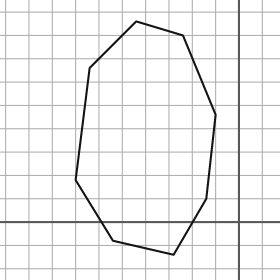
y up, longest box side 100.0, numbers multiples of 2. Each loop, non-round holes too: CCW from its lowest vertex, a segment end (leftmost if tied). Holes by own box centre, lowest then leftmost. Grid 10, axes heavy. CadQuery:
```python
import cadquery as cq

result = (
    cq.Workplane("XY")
    .moveTo(-28.0, -14.0)
    .lineTo(-14.0, 10.0)
    .lineTo(-10.0, 46.0)
    .lineTo(-24.0, 80.0)
    .lineTo(-44.0, 86.0)
    .lineTo(-64.0, 66.0)
    .lineTo(-70.0, 18.0)
    .lineTo(-54.0, -8.0)
    .close()
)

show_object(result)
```